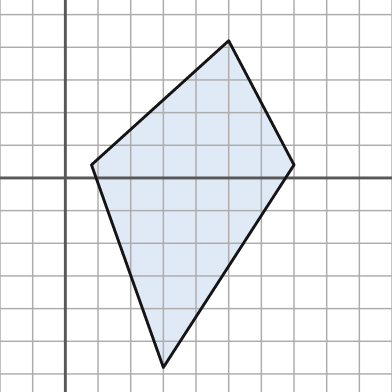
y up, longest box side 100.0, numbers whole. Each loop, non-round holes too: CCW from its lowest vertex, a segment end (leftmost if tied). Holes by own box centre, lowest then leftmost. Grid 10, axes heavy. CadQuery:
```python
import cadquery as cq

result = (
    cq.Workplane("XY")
    .moveTo(30.0, -58.0)
    .lineTo(70.0, 4.0)
    .lineTo(50.0, 42.0)
    .lineTo(8.0, 4.0)
    .close()
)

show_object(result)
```